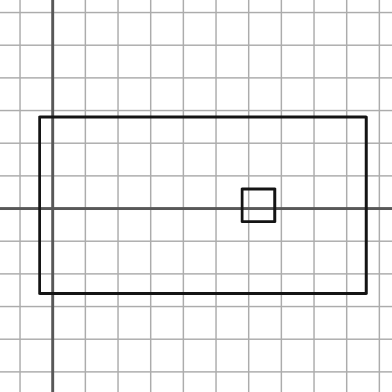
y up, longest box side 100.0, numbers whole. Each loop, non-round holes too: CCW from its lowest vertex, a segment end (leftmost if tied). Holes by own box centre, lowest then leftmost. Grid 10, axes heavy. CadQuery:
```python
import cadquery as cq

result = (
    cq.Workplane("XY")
    .moveTo(-4.0, -26.0)
    .lineTo(96.0, -26.0)
    .lineTo(96.0, 28.0)
    .lineTo(-4.0, 28.0)
    .close()
    .moveTo(58.0, -4.0)
    .lineTo(68.0, -4.0)
    .lineTo(68.0, 6.0)
    .lineTo(58.0, 6.0)
    .close()
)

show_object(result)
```